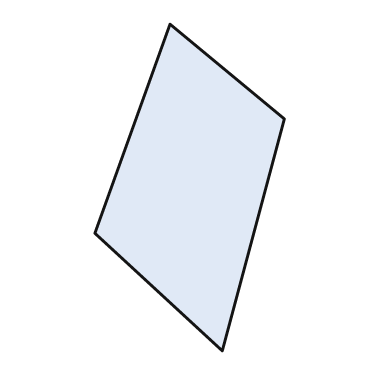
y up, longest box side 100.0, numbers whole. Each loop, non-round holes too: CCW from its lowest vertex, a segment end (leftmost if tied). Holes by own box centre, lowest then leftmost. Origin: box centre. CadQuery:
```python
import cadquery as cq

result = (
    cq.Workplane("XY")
    .moveTo(10.0, -50.0)
    .lineTo(29.0, 21.0)
    .lineTo(-6.0, 50.0)
    .lineTo(-29.0, -14.0)
    .close()
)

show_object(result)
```